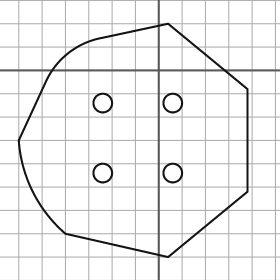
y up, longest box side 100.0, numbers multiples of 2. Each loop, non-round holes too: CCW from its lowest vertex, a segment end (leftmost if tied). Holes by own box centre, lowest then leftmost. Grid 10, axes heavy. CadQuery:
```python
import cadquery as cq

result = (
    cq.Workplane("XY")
    .moveTo(4.0, -80.0)
    .lineTo(38.0, -52.0)
    .lineTo(38.0, -8.0)
    .lineTo(4.0, 20.0)
    .lineTo(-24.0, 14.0)
    .threePointArc((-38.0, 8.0), (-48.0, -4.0))
    .lineTo(-60.0, -30.0)
    .threePointArc((-54.0, -52.0), (-40.0, -70.0))
    .close()
    .moveTo(-24.0, -44.0)
    .circle(4.0)
    .moveTo(6.0, -44.0)
    .circle(4.0)
    .moveTo(-24.0, -14.0)
    .circle(4.0)
    .moveTo(6.0, -14.0)
    .circle(4.0)
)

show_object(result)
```